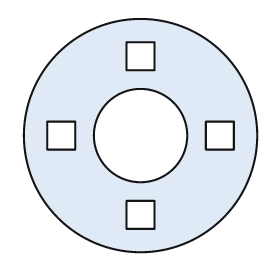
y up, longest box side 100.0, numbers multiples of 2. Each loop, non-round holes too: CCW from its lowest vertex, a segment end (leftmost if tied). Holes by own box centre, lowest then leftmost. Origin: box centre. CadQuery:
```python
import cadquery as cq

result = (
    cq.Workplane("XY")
    .moveTo(0.0, 0.0)
    .circle(50.0)
    .moveTo(-6.0, -40.0)
    .lineTo(6.0, -40.0)
    .lineTo(6.0, -28.0)
    .lineTo(-6.0, -28.0)
    .close()
    .moveTo(-40.0, -6.0)
    .lineTo(-28.0, -6.0)
    .lineTo(-28.0, 6.0)
    .lineTo(-40.0, 6.0)
    .close()
    .moveTo(0.0, 0.0)
    .circle(20.0)
    .moveTo(28.0, -6.0)
    .lineTo(40.0, -6.0)
    .lineTo(40.0, 6.0)
    .lineTo(28.0, 6.0)
    .close()
    .moveTo(-6.0, 28.0)
    .lineTo(6.0, 28.0)
    .lineTo(6.0, 40.0)
    .lineTo(-6.0, 40.0)
    .close()
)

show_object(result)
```